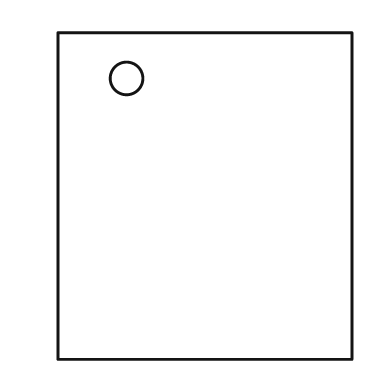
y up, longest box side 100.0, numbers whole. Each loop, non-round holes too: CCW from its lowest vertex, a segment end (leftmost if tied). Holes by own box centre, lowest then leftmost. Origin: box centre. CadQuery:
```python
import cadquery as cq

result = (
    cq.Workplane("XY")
    .moveTo(-45.0, -50.0)
    .lineTo(45.0, -50.0)
    .lineTo(45.0, 50.0)
    .lineTo(-45.0, 50.0)
    .close()
    .moveTo(-24.0, 36.0)
    .circle(5.0)
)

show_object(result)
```